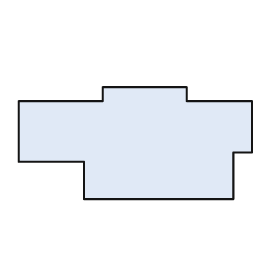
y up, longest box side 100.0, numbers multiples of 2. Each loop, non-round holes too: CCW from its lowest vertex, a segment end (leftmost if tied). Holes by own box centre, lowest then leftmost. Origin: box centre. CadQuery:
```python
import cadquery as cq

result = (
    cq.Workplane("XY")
    .moveTo(-22.0, -24.0)
    .lineTo(42.0, -24.0)
    .lineTo(42.0, -4.0)
    .lineTo(50.0, -4.0)
    .lineTo(50.0, 18.0)
    .lineTo(22.0, 18.0)
    .lineTo(22.0, 24.0)
    .lineTo(-14.0, 24.0)
    .lineTo(-14.0, 18.0)
    .lineTo(-50.0, 18.0)
    .lineTo(-50.0, -8.0)
    .lineTo(-22.0, -8.0)
    .close()
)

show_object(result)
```